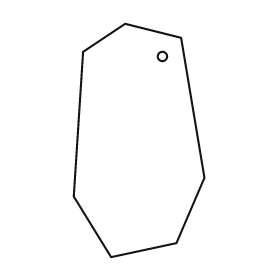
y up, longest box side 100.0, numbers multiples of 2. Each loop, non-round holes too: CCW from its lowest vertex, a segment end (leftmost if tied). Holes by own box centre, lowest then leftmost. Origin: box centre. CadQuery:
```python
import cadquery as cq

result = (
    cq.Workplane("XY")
    .moveTo(-12.0, -50.0)
    .lineTo(16.0, -44.0)
    .lineTo(28.0, -16.0)
    .lineTo(18.0, 44.0)
    .lineTo(-6.0, 50.0)
    .lineTo(-24.0, 38.0)
    .lineTo(-28.0, -24.0)
    .close()
    .moveTo(10.0, 36.0)
    .circle(2.0)
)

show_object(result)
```